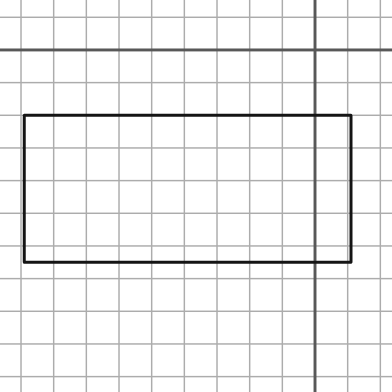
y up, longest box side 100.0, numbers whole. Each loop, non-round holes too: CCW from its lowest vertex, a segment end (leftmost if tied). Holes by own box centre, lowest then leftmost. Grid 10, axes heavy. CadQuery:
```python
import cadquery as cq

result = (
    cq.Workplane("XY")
    .moveTo(-89.0, -65.0)
    .lineTo(11.0, -65.0)
    .lineTo(11.0, -20.0)
    .lineTo(-89.0, -20.0)
    .close()
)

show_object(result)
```